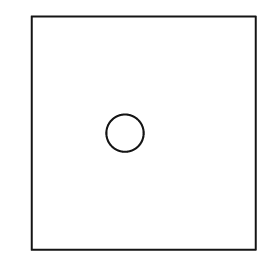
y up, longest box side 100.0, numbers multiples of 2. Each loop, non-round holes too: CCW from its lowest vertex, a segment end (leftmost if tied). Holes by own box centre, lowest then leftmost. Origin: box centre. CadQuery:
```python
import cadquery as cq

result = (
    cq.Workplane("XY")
    .moveTo(-48.0, -50.0)
    .lineTo(48.0, -50.0)
    .lineTo(48.0, 50.0)
    .lineTo(-48.0, 50.0)
    .close()
    .moveTo(-8.0, 0.0)
    .circle(8.0)
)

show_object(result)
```